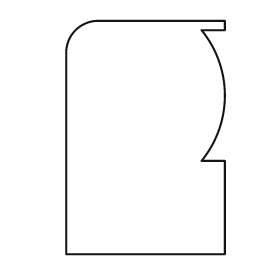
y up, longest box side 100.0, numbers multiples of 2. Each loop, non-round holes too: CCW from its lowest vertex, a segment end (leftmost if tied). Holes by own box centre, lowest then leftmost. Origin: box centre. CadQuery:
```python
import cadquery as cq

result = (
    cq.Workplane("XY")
    .moveTo(-34.0, -50.0)
    .lineTo(34.0, -50.0)
    .lineTo(34.0, -10.0)
    .lineTo(24.0, -10.0)
    .threePointArc((34.0, 18.0), (24.0, 46.0))
    .lineTo(34.0, 46.0)
    .lineTo(34.0, 50.0)
    .lineTo(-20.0, 50.0)
    .threePointArc((-30.0, 46.0), (-34.0, 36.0))
    .close()
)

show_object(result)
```